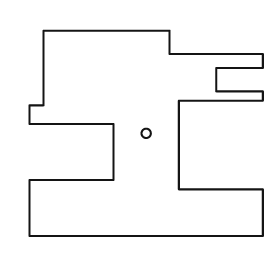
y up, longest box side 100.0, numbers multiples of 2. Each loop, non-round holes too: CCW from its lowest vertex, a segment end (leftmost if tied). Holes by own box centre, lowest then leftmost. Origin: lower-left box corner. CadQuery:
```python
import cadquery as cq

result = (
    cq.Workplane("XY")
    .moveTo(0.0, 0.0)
    .lineTo(100.0, 0.0)
    .lineTo(100.0, 20.0)
    .lineTo(64.0, 20.0)
    .lineTo(64.0, 58.0)
    .lineTo(100.0, 58.0)
    .lineTo(100.0, 62.0)
    .lineTo(80.0, 62.0)
    .lineTo(80.0, 72.0)
    .lineTo(100.0, 72.0)
    .lineTo(100.0, 78.0)
    .lineTo(60.0, 78.0)
    .lineTo(60.0, 88.0)
    .lineTo(6.0, 88.0)
    .lineTo(6.0, 56.0)
    .lineTo(0.0, 56.0)
    .lineTo(0.0, 48.0)
    .lineTo(36.0, 48.0)
    .lineTo(36.0, 24.0)
    .lineTo(0.0, 24.0)
    .close()
    .moveTo(50.0, 44.0)
    .circle(2.0)
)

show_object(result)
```